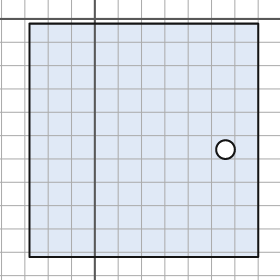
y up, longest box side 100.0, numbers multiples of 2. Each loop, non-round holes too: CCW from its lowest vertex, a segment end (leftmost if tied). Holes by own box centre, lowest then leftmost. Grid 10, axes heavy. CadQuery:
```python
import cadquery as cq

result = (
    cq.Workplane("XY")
    .moveTo(-28.0, -102.0)
    .lineTo(70.0, -102.0)
    .lineTo(70.0, -2.0)
    .lineTo(-28.0, -2.0)
    .close()
    .moveTo(56.0, -56.0)
    .circle(4.0)
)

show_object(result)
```